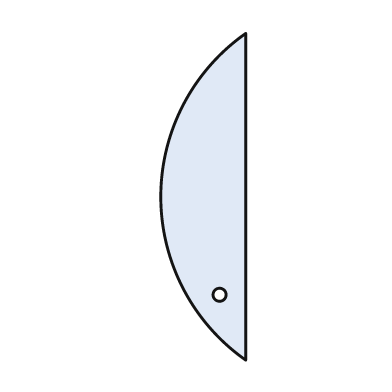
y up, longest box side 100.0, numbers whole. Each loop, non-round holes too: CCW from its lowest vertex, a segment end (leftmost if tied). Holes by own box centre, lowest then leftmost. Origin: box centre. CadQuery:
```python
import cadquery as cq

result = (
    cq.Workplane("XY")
    .moveTo(13.0, -50.0)
    .lineTo(13.0, 50.0)
    .threePointArc((-13.0, 0.0), (13.0, -50.0))
    .close()
    .moveTo(5.0, -30.0)
    .circle(2.0)
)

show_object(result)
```